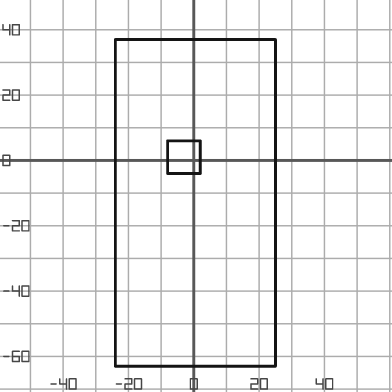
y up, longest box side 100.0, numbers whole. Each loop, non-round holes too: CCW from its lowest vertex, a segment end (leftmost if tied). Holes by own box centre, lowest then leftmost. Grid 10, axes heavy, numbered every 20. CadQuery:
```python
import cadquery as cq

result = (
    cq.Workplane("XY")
    .moveTo(-24.0, -63.0)
    .lineTo(25.0, -63.0)
    .lineTo(25.0, 37.0)
    .lineTo(-24.0, 37.0)
    .close()
    .moveTo(-8.0, -4.0)
    .lineTo(2.0, -4.0)
    .lineTo(2.0, 6.0)
    .lineTo(-8.0, 6.0)
    .close()
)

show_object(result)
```